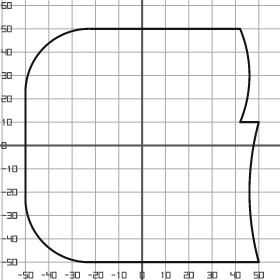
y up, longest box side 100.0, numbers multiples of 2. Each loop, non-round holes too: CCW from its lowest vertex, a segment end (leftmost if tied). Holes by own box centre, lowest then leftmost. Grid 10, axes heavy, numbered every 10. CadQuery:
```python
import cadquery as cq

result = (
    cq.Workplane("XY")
    .moveTo(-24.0, -50.0)
    .lineTo(50.0, -50.0)
    .threePointArc((46.0, -20.0), (50.0, 10.0))
    .lineTo(42.0, 10.0)
    .threePointArc((46.0, 30.0), (42.0, 50.0))
    .lineTo(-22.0, 50.0)
    .threePointArc((-42.0, 42.0), (-50.0, 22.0))
    .lineTo(-50.0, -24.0)
    .threePointArc((-42.0, -42.0), (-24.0, -50.0))
    .close()
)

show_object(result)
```